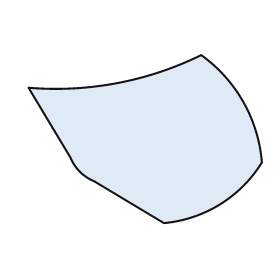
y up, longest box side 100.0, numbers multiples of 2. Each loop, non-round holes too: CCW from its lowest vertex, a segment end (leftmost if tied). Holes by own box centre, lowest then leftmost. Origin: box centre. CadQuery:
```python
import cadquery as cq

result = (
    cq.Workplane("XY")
    .moveTo(8.0, -36.0)
    .threePointArc((32.0, -28.0), (50.0, -10.0))
    .threePointArc((42.0, 16.0), (24.0, 36.0))
    .threePointArc((-12.0, 24.0), (-50.0, 22.0))
    .lineTo(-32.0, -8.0)
    .threePointArc((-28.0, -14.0), (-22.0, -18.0))
    .close()
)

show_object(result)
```